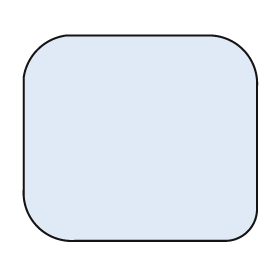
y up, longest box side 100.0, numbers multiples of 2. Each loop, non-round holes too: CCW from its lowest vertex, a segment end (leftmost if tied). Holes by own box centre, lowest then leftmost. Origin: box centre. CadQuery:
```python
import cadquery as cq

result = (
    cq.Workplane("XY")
    .moveTo(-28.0, -44.0)
    .lineTo(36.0, -44.0)
    .threePointArc((46.0, -40.0), (50.0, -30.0))
    .lineTo(50.0, 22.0)
    .threePointArc((44.0, 38.0), (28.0, 44.0))
    .lineTo(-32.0, 44.0)
    .threePointArc((-44.0, 38.0), (-50.0, 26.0))
    .lineTo(-50.0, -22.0)
    .threePointArc((-44.0, -38.0), (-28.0, -44.0))
    .close()
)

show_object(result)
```